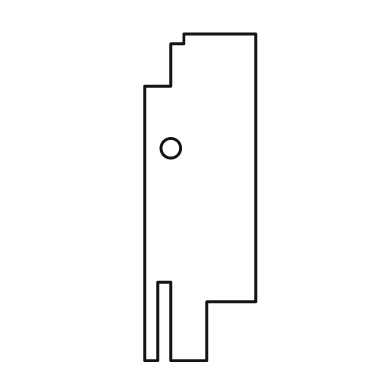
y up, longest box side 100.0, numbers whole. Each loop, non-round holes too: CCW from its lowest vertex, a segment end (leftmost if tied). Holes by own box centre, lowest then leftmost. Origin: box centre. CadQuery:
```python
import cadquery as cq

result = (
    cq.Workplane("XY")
    .moveTo(-17.0, -50.0)
    .lineTo(-13.0, -50.0)
    .lineTo(-13.0, -26.0)
    .lineTo(-9.0, -26.0)
    .lineTo(-9.0, -50.0)
    .lineTo(2.0, -50.0)
    .lineTo(2.0, -32.0)
    .lineTo(17.0, -32.0)
    .lineTo(17.0, 50.0)
    .lineTo(-5.0, 50.0)
    .lineTo(-5.0, 47.0)
    .lineTo(-9.0, 47.0)
    .lineTo(-9.0, 34.0)
    .lineTo(-17.0, 34.0)
    .close()
    .moveTo(-9.0, 15.0)
    .circle(3.0)
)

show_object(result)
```